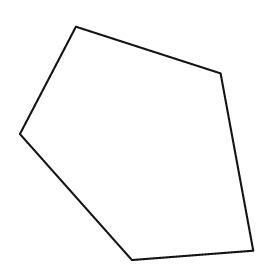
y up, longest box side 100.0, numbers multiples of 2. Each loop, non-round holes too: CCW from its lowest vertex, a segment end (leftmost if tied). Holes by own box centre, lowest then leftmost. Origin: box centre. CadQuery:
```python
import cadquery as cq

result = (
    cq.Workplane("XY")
    .moveTo(-2.0, -50.0)
    .lineTo(50.0, -46.0)
    .lineTo(36.0, 30.0)
    .lineTo(-26.0, 50.0)
    .lineTo(-50.0, 4.0)
    .close()
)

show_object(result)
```